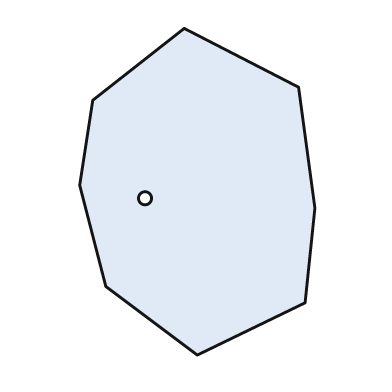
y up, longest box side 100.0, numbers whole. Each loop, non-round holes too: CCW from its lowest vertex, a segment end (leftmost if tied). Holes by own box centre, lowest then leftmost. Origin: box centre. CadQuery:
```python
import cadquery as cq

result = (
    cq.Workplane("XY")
    .moveTo(0.0, -50.0)
    .lineTo(33.0, -34.0)
    .lineTo(36.0, -5.0)
    .lineTo(31.0, 32.0)
    .lineTo(-4.0, 50.0)
    .lineTo(-32.0, 28.0)
    .lineTo(-36.0, 2.0)
    .lineTo(-28.0, -29.0)
    .close()
    .moveTo(-16.0, -2.0)
    .circle(2.0)
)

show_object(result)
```